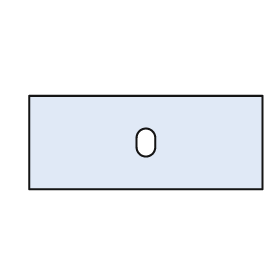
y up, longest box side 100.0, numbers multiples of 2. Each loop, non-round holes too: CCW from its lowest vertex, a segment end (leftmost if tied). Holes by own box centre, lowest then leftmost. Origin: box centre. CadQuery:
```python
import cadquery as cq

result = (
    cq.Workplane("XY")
    .moveTo(-50.0, -20.0)
    .lineTo(50.0, -20.0)
    .lineTo(50.0, 20.0)
    .lineTo(-50.0, 20.0)
    .close()
    .moveTo(-4.0, -2.0)
    .threePointArc((0.0, -6.0), (4.0, -2.0))
    .lineTo(4.0, 2.0)
    .threePointArc((0.0, 6.0), (-4.0, 2.0))
    .close()
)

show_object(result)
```